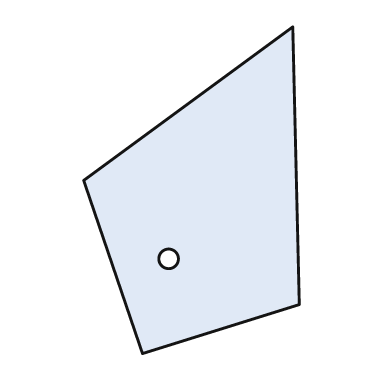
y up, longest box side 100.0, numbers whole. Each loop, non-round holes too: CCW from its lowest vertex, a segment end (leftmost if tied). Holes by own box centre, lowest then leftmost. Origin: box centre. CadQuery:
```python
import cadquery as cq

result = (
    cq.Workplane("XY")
    .moveTo(-15.0, -50.0)
    .lineTo(33.0, -35.0)
    .lineTo(31.0, 50.0)
    .lineTo(-33.0, 3.0)
    .close()
    .moveTo(-7.0, -21.0)
    .circle(3.0)
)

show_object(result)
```